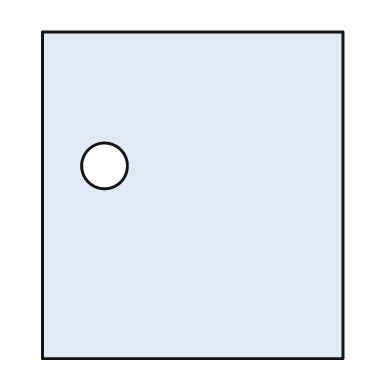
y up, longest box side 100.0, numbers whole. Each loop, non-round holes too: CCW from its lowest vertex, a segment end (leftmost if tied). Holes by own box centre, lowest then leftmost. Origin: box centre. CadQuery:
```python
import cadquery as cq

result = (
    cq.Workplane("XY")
    .moveTo(-46.0, -50.0)
    .lineTo(46.0, -50.0)
    .lineTo(46.0, 50.0)
    .lineTo(-46.0, 50.0)
    .close()
    .moveTo(-27.0, 9.0)
    .circle(7.0)
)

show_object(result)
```